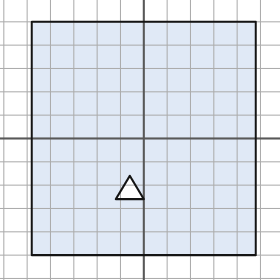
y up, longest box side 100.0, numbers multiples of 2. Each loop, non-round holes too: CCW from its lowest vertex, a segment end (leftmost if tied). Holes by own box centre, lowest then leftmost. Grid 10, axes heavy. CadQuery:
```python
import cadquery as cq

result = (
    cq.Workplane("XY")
    .moveTo(-48.0, -50.0)
    .lineTo(48.0, -50.0)
    .lineTo(48.0, 50.0)
    .lineTo(-48.0, 50.0)
    .close()
    .moveTo(-12.0, -26.0)
    .lineTo(0.0, -26.0)
    .lineTo(-6.0, -16.0)
    .close()
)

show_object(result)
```